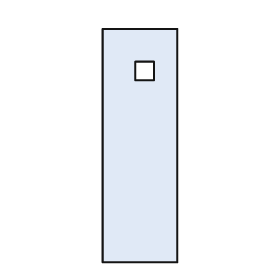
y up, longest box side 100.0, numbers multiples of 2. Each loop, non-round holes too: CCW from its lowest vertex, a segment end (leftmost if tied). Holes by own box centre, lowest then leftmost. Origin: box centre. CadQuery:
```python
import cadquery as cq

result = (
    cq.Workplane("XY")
    .moveTo(-16.0, -50.0)
    .lineTo(16.0, -50.0)
    .lineTo(16.0, 50.0)
    .lineTo(-16.0, 50.0)
    .close()
    .moveTo(-2.0, 28.0)
    .lineTo(6.0, 28.0)
    .lineTo(6.0, 36.0)
    .lineTo(-2.0, 36.0)
    .close()
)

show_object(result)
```